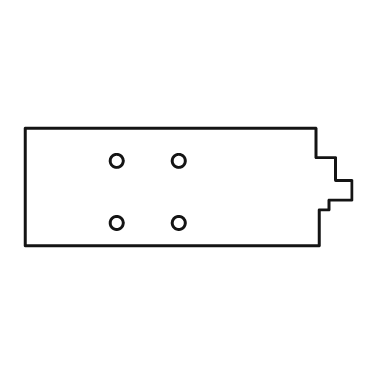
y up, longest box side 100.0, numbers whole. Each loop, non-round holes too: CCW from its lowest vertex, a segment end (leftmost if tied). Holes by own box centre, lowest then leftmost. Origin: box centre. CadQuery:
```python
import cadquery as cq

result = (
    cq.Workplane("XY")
    .moveTo(-50.0, -18.0)
    .lineTo(40.0, -18.0)
    .lineTo(40.0, -7.0)
    .lineTo(43.0, -7.0)
    .lineTo(43.0, -4.0)
    .lineTo(50.0, -4.0)
    .lineTo(50.0, 2.0)
    .lineTo(45.0, 2.0)
    .lineTo(45.0, 9.0)
    .lineTo(39.0, 9.0)
    .lineTo(39.0, 18.0)
    .lineTo(-50.0, 18.0)
    .close()
    .moveTo(-22.0, -11.0)
    .circle(2.0)
    .moveTo(-3.0, -11.0)
    .circle(2.0)
    .moveTo(-22.0, 8.0)
    .circle(2.0)
    .moveTo(-3.0, 8.0)
    .circle(2.0)
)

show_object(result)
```